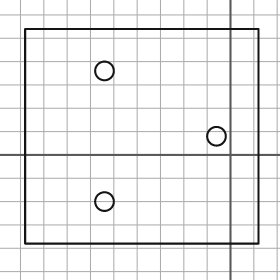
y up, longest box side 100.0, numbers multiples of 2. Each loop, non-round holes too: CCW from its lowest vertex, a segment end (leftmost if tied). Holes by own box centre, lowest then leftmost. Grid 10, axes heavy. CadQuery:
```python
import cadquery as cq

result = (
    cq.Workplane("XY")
    .moveTo(-88.0, -38.0)
    .lineTo(12.0, -38.0)
    .lineTo(12.0, 54.0)
    .lineTo(-88.0, 54.0)
    .close()
    .moveTo(-54.0, -20.0)
    .circle(4.0)
    .moveTo(-6.0, 8.0)
    .circle(4.0)
    .moveTo(-54.0, 36.0)
    .circle(4.0)
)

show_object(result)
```